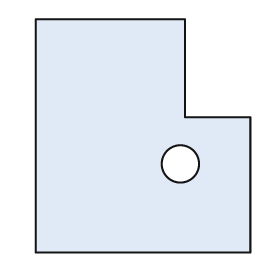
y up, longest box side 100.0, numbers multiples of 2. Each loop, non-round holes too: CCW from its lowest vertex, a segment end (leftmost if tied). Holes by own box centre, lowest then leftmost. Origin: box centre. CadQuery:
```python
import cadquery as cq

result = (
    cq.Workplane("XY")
    .moveTo(-46.0, -50.0)
    .lineTo(46.0, -50.0)
    .lineTo(46.0, 8.0)
    .lineTo(18.0, 8.0)
    .lineTo(18.0, 50.0)
    .lineTo(-46.0, 50.0)
    .close()
    .moveTo(16.0, -12.0)
    .circle(8.0)
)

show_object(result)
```